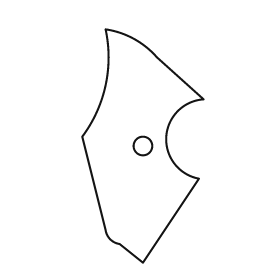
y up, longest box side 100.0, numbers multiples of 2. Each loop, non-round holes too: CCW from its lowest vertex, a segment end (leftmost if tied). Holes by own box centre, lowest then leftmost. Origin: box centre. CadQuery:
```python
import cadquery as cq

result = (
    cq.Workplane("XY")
    .moveTo(0.0, -50.0)
    .lineTo(24.0, -14.0)
    .threePointArc((10.0, 4.0), (26.0, 20.0))
    .lineTo(6.0, 38.0)
    .threePointArc((-4.0, 46.0), (-16.0, 50.0))
    .threePointArc((-16.0, 26.0), (-26.0, 4.0))
    .lineTo(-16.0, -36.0)
    .threePointArc((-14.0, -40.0), (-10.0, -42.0))
    .close()
    .moveTo(0.0, 0.0)
    .circle(4.0)
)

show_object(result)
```